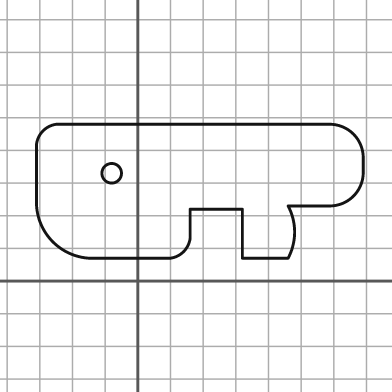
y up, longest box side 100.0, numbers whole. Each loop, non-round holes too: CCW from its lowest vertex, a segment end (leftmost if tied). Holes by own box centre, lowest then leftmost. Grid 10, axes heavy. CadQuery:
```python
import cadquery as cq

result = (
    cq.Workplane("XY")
    .moveTo(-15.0, 7.0)
    .lineTo(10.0, 7.0)
    .threePointArc((14.0, 9.0), (16.0, 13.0))
    .lineTo(16.0, 22.0)
    .lineTo(32.0, 22.0)
    .lineTo(32.0, 7.0)
    .lineTo(46.0, 7.0)
    .threePointArc((48.0, 15.0), (46.0, 23.0))
    .lineTo(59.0, 23.0)
    .threePointArc((66.0, 26.0), (69.0, 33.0))
    .lineTo(69.0, 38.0)
    .threePointArc((66.0, 45.0), (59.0, 48.0))
    .lineTo(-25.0, 48.0)
    .threePointArc((-29.0, 46.0), (-31.0, 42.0))
    .lineTo(-31.0, 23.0)
    .threePointArc((-26.0, 12.0), (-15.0, 7.0))
    .close()
    .moveTo(-8.0, 33.0)
    .circle(3.0)
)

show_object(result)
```